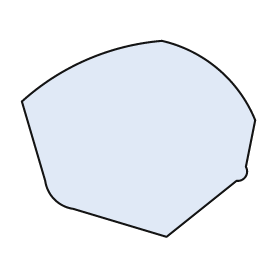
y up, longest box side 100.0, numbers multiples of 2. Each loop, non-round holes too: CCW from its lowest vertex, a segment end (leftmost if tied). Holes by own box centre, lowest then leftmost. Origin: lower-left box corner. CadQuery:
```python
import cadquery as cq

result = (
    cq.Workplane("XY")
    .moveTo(62.0, 0.0)
    .lineTo(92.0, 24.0)
    .threePointArc((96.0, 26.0), (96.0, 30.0))
    .lineTo(100.0, 50.0)
    .threePointArc((84.0, 72.0), (60.0, 84.0))
    .threePointArc((28.0, 76.0), (0.0, 58.0))
    .lineTo(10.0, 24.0)
    .threePointArc((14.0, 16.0), (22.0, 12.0))
    .close()
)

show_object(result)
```